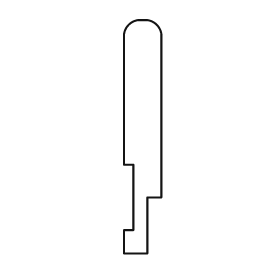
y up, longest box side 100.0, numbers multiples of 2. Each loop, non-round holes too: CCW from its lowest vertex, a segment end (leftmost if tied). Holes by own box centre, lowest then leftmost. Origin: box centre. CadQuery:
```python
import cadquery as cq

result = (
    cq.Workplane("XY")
    .moveTo(-8.0, -50.0)
    .lineTo(2.0, -50.0)
    .lineTo(2.0, -26.0)
    .lineTo(8.0, -26.0)
    .lineTo(8.0, 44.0)
    .threePointArc((6.0, 48.0), (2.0, 50.0))
    .lineTo(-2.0, 50.0)
    .threePointArc((-6.0, 48.0), (-8.0, 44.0))
    .lineTo(-8.0, -12.0)
    .lineTo(-4.0, -12.0)
    .lineTo(-4.0, -40.0)
    .lineTo(-8.0, -40.0)
    .close()
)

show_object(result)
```